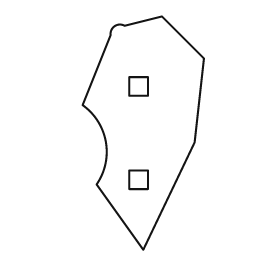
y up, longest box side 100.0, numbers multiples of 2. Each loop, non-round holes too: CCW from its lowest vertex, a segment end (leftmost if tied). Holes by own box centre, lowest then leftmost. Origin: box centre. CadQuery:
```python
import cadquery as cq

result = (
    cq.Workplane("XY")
    .moveTo(0.0, -50.0)
    .lineTo(22.0, -4.0)
    .lineTo(26.0, 32.0)
    .lineTo(8.0, 50.0)
    .lineTo(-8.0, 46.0)
    .threePointArc((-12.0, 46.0), (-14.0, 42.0))
    .lineTo(-26.0, 12.0)
    .threePointArc((-16.0, -4.0), (-20.0, -22.0))
    .close()
    .moveTo(-6.0, -24.0)
    .lineTo(2.0, -24.0)
    .lineTo(2.0, -16.0)
    .lineTo(-6.0, -16.0)
    .close()
    .moveTo(-6.0, 16.0)
    .lineTo(2.0, 16.0)
    .lineTo(2.0, 24.0)
    .lineTo(-6.0, 24.0)
    .close()
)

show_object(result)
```